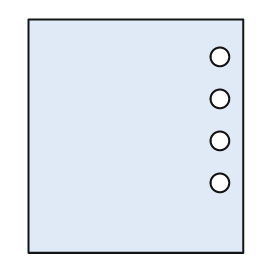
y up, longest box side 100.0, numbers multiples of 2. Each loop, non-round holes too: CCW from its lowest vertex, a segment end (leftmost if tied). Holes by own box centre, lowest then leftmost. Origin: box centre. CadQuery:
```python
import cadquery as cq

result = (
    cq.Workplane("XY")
    .moveTo(-46.0, -50.0)
    .lineTo(46.0, -50.0)
    .lineTo(46.0, 50.0)
    .lineTo(-46.0, 50.0)
    .close()
    .moveTo(36.0, -20.0)
    .circle(4.0)
    .moveTo(36.0, -2.0)
    .circle(4.0)
    .moveTo(36.0, 16.0)
    .circle(4.0)
    .moveTo(36.0, 34.0)
    .circle(4.0)
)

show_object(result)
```